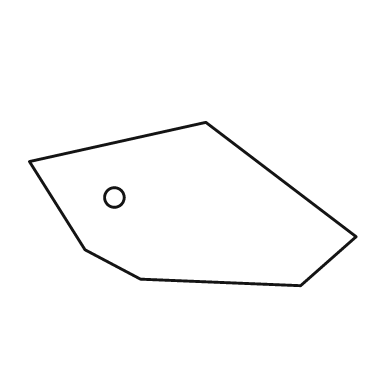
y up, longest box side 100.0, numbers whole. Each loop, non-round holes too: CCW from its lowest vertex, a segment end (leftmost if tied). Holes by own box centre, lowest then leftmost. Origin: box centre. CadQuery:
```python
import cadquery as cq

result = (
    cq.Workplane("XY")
    .moveTo(33.0, -25.0)
    .lineTo(50.0, -10.0)
    .lineTo(4.0, 25.0)
    .lineTo(-50.0, 13.0)
    .lineTo(-33.0, -14.0)
    .lineTo(-16.0, -23.0)
    .close()
    .moveTo(-24.0, 2.0)
    .circle(3.0)
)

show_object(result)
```